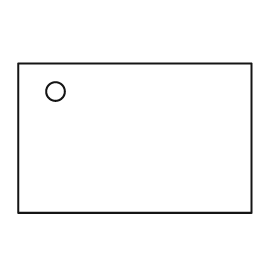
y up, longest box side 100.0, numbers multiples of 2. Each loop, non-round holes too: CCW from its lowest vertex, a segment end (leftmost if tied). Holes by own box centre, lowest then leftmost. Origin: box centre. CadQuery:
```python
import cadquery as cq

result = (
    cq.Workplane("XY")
    .moveTo(-50.0, -32.0)
    .lineTo(50.0, -32.0)
    .lineTo(50.0, 32.0)
    .lineTo(-50.0, 32.0)
    .close()
    .moveTo(-34.0, 20.0)
    .circle(4.0)
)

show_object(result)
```